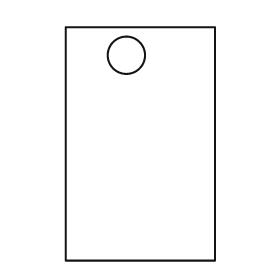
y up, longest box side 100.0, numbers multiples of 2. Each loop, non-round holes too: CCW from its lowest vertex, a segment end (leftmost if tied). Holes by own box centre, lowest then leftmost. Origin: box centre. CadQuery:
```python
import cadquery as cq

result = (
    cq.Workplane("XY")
    .moveTo(-32.0, -50.0)
    .lineTo(32.0, -50.0)
    .lineTo(32.0, 50.0)
    .lineTo(-32.0, 50.0)
    .close()
    .moveTo(-6.0, 38.0)
    .circle(8.0)
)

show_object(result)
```